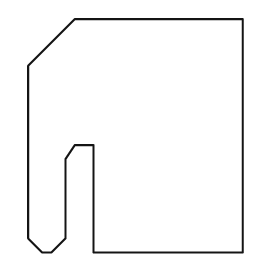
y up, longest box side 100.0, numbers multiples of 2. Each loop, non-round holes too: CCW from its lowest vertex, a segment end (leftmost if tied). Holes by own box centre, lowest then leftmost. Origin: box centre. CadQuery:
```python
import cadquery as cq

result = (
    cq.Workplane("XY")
    .moveTo(-40.0, -50.0)
    .lineTo(-36.0, -50.0)
    .lineTo(-30.0, -44.0)
    .lineTo(-30.0, -10.0)
    .lineTo(-26.0, -4.0)
    .lineTo(-18.0, -4.0)
    .lineTo(-18.0, -50.0)
    .lineTo(46.0, -50.0)
    .lineTo(46.0, 50.0)
    .lineTo(-26.0, 50.0)
    .lineTo(-46.0, 30.0)
    .lineTo(-46.0, -44.0)
    .close()
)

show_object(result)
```